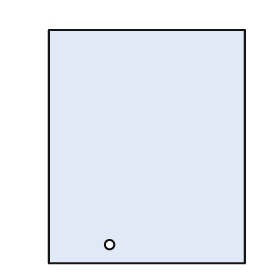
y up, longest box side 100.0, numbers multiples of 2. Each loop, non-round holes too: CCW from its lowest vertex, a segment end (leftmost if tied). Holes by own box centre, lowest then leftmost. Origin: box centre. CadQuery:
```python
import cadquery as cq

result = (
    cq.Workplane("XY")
    .moveTo(-42.0, -50.0)
    .lineTo(42.0, -50.0)
    .lineTo(42.0, 50.0)
    .lineTo(-42.0, 50.0)
    .close()
    .moveTo(-16.0, -42.0)
    .circle(2.0)
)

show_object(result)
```